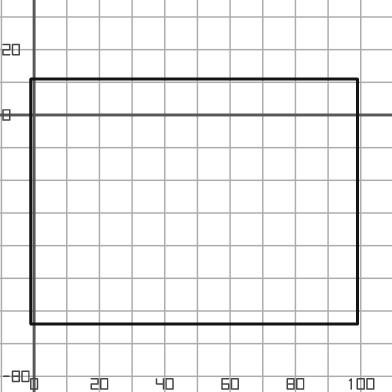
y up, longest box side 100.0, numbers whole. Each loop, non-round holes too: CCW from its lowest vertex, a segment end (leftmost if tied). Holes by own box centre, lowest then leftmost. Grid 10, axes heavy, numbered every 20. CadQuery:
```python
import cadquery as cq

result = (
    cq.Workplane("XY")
    .moveTo(-1.0, -64.0)
    .lineTo(99.0, -64.0)
    .lineTo(99.0, 11.0)
    .lineTo(-1.0, 11.0)
    .close()
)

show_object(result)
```